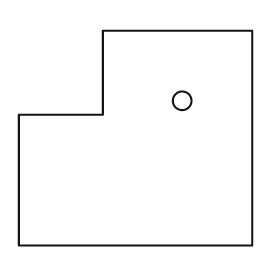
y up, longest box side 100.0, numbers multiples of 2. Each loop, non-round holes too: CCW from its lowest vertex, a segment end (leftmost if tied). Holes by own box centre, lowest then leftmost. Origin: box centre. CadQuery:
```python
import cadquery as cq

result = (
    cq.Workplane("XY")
    .moveTo(-50.0, -46.0)
    .lineTo(50.0, -46.0)
    .lineTo(50.0, 46.0)
    .lineTo(-14.0, 46.0)
    .lineTo(-14.0, 10.0)
    .lineTo(-50.0, 10.0)
    .close()
    .moveTo(20.0, 16.0)
    .circle(4.0)
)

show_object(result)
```